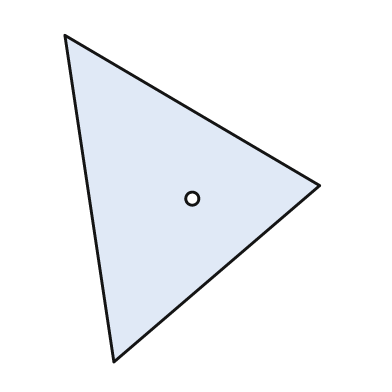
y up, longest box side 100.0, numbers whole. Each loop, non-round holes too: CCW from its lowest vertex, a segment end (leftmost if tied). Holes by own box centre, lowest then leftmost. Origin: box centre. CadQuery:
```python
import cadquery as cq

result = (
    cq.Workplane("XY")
    .moveTo(-24.0, -50.0)
    .lineTo(39.0, 4.0)
    .lineTo(-39.0, 50.0)
    .close()
    .moveTo(0.0, 0.0)
    .circle(2.0)
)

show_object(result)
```